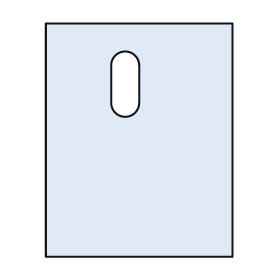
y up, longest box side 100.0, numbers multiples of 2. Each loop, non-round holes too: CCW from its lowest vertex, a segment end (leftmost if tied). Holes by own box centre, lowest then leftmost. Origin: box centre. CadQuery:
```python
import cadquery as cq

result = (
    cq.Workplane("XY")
    .moveTo(-40.0, -50.0)
    .lineTo(40.0, -50.0)
    .lineTo(40.0, 50.0)
    .lineTo(-40.0, 50.0)
    .close()
    .moveTo(-12.0, 16.0)
    .threePointArc((-6.0, 10.0), (0.0, 16.0))
    .lineTo(0.0, 32.0)
    .threePointArc((-6.0, 38.0), (-12.0, 32.0))
    .close()
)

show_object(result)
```